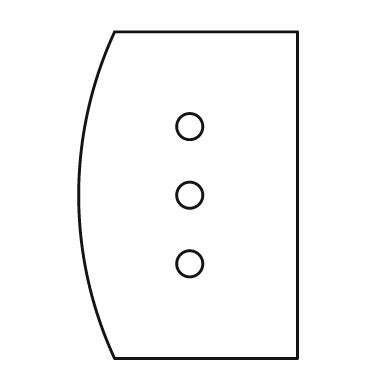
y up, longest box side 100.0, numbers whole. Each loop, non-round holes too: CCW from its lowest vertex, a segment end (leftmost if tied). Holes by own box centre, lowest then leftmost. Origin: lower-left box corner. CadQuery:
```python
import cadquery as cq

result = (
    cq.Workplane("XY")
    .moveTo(11.0, 0.0)
    .lineTo(67.0, 0.0)
    .lineTo(67.0, 100.0)
    .lineTo(11.0, 100.0)
    .threePointArc((0.0, 50.0), (11.0, 0.0))
    .close()
    .moveTo(34.0, 29.0)
    .circle(4.0)
    .moveTo(34.0, 50.0)
    .circle(4.0)
    .moveTo(34.0, 71.0)
    .circle(4.0)
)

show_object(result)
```